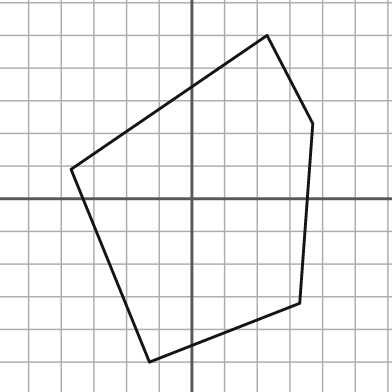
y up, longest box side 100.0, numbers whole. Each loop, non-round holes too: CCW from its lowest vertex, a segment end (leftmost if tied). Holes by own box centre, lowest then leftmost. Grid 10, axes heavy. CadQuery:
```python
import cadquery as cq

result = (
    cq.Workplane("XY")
    .moveTo(-13.0, -50.0)
    .lineTo(33.0, -32.0)
    .lineTo(37.0, 23.0)
    .lineTo(23.0, 50.0)
    .lineTo(-37.0, 9.0)
    .close()
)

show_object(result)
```